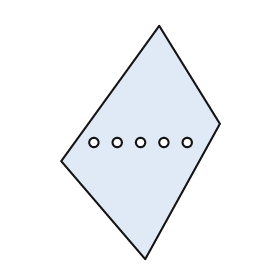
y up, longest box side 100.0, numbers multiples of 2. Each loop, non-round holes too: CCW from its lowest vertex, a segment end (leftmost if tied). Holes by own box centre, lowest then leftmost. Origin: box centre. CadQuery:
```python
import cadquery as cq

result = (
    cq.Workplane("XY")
    .moveTo(2.0, -50.0)
    .lineTo(34.0, 8.0)
    .lineTo(8.0, 50.0)
    .lineTo(-34.0, -8.0)
    .close()
    .moveTo(-20.0, 0.0)
    .circle(2.0)
    .moveTo(-10.0, 0.0)
    .circle(2.0)
    .moveTo(0.0, 0.0)
    .circle(2.0)
    .moveTo(10.0, 0.0)
    .circle(2.0)
    .moveTo(20.0, 0.0)
    .circle(2.0)
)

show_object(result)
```